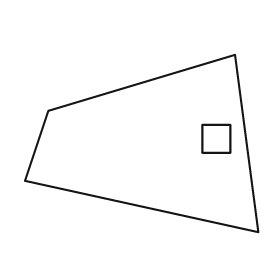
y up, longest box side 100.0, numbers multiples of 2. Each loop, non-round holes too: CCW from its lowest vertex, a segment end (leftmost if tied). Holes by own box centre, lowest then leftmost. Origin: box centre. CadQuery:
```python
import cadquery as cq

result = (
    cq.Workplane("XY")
    .moveTo(50.0, -38.0)
    .lineTo(40.0, 38.0)
    .lineTo(-40.0, 14.0)
    .lineTo(-50.0, -16.0)
    .close()
    .moveTo(26.0, -4.0)
    .lineTo(38.0, -4.0)
    .lineTo(38.0, 8.0)
    .lineTo(26.0, 8.0)
    .close()
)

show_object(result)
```